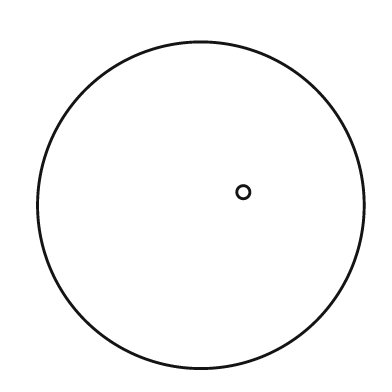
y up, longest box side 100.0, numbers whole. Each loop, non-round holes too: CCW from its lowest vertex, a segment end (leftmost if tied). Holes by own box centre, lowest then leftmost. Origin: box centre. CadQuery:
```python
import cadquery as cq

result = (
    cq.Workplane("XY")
    .moveTo(0.0, 0.0)
    .circle(50.0)
    .moveTo(13.0, 4.0)
    .circle(2.0)
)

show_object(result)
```